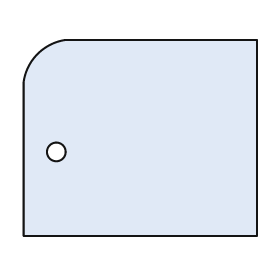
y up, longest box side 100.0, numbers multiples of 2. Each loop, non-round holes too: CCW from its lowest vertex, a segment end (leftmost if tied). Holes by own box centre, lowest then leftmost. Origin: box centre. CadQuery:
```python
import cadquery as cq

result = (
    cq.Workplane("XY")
    .moveTo(-50.0, -42.0)
    .lineTo(50.0, -42.0)
    .lineTo(50.0, 42.0)
    .lineTo(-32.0, 42.0)
    .threePointArc((-44.0, 36.0), (-50.0, 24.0))
    .close()
    .moveTo(-36.0, -6.0)
    .circle(4.0)
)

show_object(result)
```